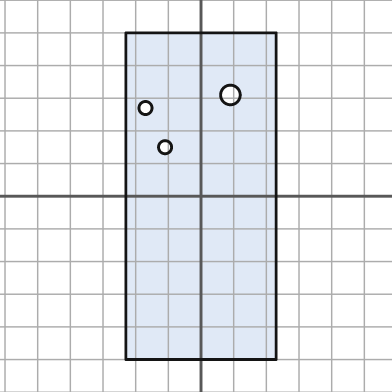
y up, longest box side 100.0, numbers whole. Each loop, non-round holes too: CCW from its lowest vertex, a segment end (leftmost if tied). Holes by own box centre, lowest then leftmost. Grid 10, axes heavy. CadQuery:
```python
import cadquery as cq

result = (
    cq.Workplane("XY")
    .moveTo(-23.0, -50.0)
    .lineTo(23.0, -50.0)
    .lineTo(23.0, 50.0)
    .lineTo(-23.0, 50.0)
    .close()
    .moveTo(-11.0, 15.0)
    .circle(2.0)
    .moveTo(-17.0, 27.0)
    .circle(2.0)
    .moveTo(9.0, 31.0)
    .circle(3.0)
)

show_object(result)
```